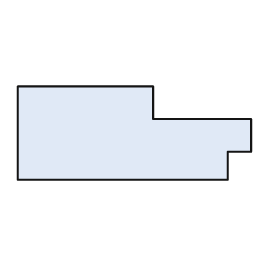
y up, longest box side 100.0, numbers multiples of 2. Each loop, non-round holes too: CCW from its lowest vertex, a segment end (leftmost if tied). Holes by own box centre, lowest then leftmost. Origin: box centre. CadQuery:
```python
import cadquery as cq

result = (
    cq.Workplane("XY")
    .moveTo(-50.0, -20.0)
    .lineTo(40.0, -20.0)
    .lineTo(40.0, -8.0)
    .lineTo(50.0, -8.0)
    .lineTo(50.0, 6.0)
    .lineTo(8.0, 6.0)
    .lineTo(8.0, 20.0)
    .lineTo(-50.0, 20.0)
    .close()
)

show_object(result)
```